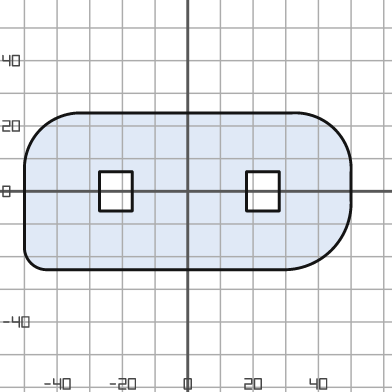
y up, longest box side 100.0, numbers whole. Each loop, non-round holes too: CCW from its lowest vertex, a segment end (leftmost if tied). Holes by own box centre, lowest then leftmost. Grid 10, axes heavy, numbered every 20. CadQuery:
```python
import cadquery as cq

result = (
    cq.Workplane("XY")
    .moveTo(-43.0, -24.0)
    .lineTo(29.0, -24.0)
    .threePointArc((44.0, -18.0), (50.0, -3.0))
    .lineTo(50.0, 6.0)
    .threePointArc((45.0, 19.0), (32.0, 24.0))
    .lineTo(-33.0, 24.0)
    .threePointArc((-45.0, 19.0), (-50.0, 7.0))
    .lineTo(-50.0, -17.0)
    .threePointArc((-48.0, -22.0), (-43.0, -24.0))
    .close()
    .moveTo(-27.0, -6.0)
    .lineTo(-17.0, -6.0)
    .lineTo(-17.0, 6.0)
    .lineTo(-27.0, 6.0)
    .close()
    .moveTo(18.0, -6.0)
    .lineTo(28.0, -6.0)
    .lineTo(28.0, 6.0)
    .lineTo(18.0, 6.0)
    .close()
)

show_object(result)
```